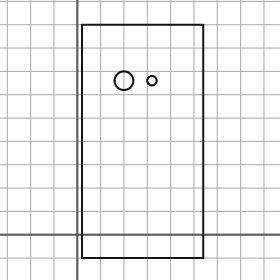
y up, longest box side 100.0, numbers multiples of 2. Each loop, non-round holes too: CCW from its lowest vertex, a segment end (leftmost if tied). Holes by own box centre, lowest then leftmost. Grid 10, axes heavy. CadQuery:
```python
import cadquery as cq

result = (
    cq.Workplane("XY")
    .moveTo(2.0, -10.0)
    .lineTo(54.0, -10.0)
    .lineTo(54.0, 90.0)
    .lineTo(2.0, 90.0)
    .close()
    .moveTo(20.0, 66.0)
    .circle(4.0)
    .moveTo(32.0, 66.0)
    .circle(2.0)
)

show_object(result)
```